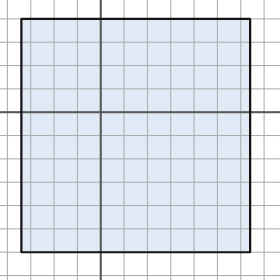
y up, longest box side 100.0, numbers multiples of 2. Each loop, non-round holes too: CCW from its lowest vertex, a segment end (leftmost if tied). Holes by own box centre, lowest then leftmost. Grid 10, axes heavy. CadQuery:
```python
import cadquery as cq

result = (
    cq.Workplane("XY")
    .moveTo(-34.0, -60.0)
    .lineTo(64.0, -60.0)
    .lineTo(64.0, 40.0)
    .lineTo(-34.0, 40.0)
    .close()
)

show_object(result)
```